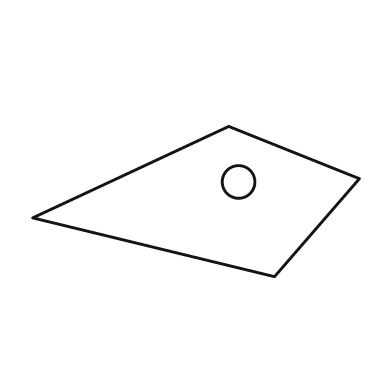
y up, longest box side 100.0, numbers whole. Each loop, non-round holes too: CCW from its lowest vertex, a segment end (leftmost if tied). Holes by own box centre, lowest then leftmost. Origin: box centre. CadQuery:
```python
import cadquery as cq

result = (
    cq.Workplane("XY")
    .moveTo(24.0, -23.0)
    .lineTo(50.0, 7.0)
    .lineTo(10.0, 23.0)
    .lineTo(-50.0, -5.0)
    .close()
    .moveTo(13.0, 6.0)
    .circle(5.0)
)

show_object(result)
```